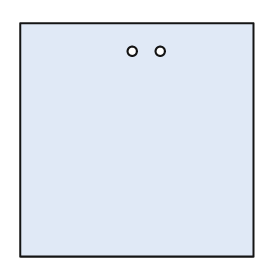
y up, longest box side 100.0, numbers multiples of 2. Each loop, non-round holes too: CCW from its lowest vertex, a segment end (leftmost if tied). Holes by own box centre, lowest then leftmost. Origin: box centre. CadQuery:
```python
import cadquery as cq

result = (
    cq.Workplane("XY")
    .moveTo(-50.0, -50.0)
    .lineTo(50.0, -50.0)
    .lineTo(50.0, 50.0)
    .lineTo(-50.0, 50.0)
    .close()
    .moveTo(-2.0, 38.0)
    .circle(2.0)
    .moveTo(10.0, 38.0)
    .circle(2.0)
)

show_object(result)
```